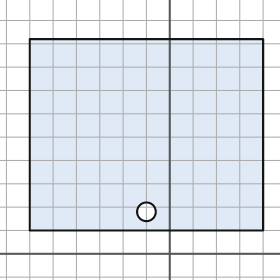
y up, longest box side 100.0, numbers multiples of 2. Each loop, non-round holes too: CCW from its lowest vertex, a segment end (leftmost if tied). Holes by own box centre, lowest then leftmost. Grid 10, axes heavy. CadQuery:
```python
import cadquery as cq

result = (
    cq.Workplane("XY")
    .moveTo(-60.0, 10.0)
    .lineTo(40.0, 10.0)
    .lineTo(40.0, 92.0)
    .lineTo(-60.0, 92.0)
    .close()
    .moveTo(-10.0, 18.0)
    .circle(4.0)
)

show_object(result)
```